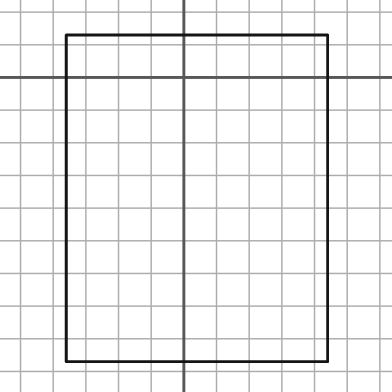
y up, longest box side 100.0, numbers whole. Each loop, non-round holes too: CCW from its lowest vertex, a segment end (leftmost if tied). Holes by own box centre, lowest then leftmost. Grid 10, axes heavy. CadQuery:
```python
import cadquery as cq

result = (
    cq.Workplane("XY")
    .moveTo(-36.0, -87.0)
    .lineTo(44.0, -87.0)
    .lineTo(44.0, 13.0)
    .lineTo(-36.0, 13.0)
    .close()
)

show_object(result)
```